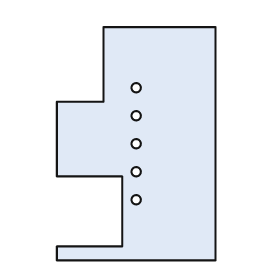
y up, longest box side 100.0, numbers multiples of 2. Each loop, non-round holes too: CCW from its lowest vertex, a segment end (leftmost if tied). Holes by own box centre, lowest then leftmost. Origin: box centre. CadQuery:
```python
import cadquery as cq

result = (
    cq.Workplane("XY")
    .moveTo(-34.0, -50.0)
    .lineTo(34.0, -50.0)
    .lineTo(34.0, 50.0)
    .lineTo(-14.0, 50.0)
    .lineTo(-14.0, 18.0)
    .lineTo(-34.0, 18.0)
    .lineTo(-34.0, -14.0)
    .lineTo(-6.0, -14.0)
    .lineTo(-6.0, -44.0)
    .lineTo(-34.0, -44.0)
    .close()
    .moveTo(0.0, -24.0)
    .circle(2.0)
    .moveTo(0.0, -12.0)
    .circle(2.0)
    .moveTo(0.0, 0.0)
    .circle(2.0)
    .moveTo(0.0, 12.0)
    .circle(2.0)
    .moveTo(0.0, 24.0)
    .circle(2.0)
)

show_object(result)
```